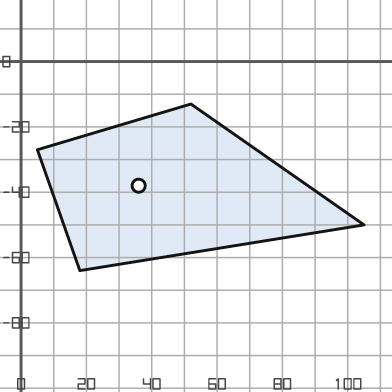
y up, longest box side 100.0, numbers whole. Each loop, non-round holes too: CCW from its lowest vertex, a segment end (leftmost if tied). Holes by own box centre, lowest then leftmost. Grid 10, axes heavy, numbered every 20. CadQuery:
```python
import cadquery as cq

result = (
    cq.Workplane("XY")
    .moveTo(18.0, -64.0)
    .lineTo(105.0, -50.0)
    .lineTo(52.0, -13.0)
    .lineTo(5.0, -27.0)
    .close()
    .moveTo(36.0, -38.0)
    .circle(2.0)
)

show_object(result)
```